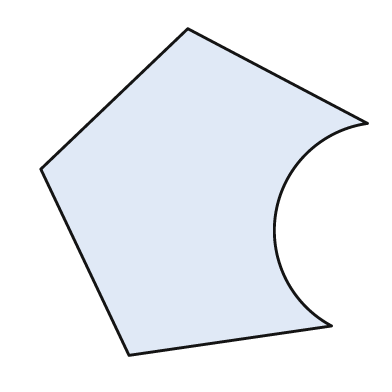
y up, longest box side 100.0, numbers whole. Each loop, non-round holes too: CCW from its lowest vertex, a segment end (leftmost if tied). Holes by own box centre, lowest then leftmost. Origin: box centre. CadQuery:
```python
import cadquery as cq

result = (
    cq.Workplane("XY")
    .moveTo(-23.0, -50.0)
    .lineTo(39.0, -41.0)
    .threePointArc((22.0, -6.0), (50.0, 21.0))
    .lineTo(-5.0, 50.0)
    .lineTo(-50.0, 7.0)
    .close()
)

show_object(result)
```